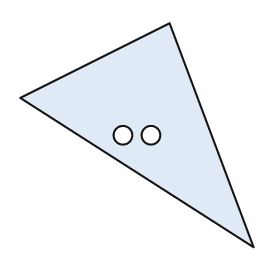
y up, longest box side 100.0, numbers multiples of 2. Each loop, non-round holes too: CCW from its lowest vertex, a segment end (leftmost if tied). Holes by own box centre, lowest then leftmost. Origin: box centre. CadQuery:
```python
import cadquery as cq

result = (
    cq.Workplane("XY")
    .moveTo(50.0, -48.0)
    .lineTo(14.0, 48.0)
    .lineTo(-50.0, 16.0)
    .close()
    .moveTo(-6.0, 0.0)
    .circle(4.0)
    .moveTo(6.0, 0.0)
    .circle(4.0)
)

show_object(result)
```